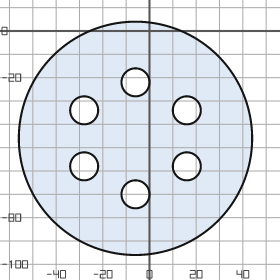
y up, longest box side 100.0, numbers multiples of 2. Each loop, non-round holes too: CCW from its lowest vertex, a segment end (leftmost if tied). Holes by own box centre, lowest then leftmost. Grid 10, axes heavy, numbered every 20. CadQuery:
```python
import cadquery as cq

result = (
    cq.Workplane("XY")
    .moveTo(-6.0, -46.0)
    .circle(50.0)
    .moveTo(-6.0, -70.0)
    .circle(6.0)
    .moveTo(-28.0, -58.0)
    .circle(6.0)
    .moveTo(16.0, -58.0)
    .circle(6.0)
    .moveTo(-28.0, -34.0)
    .circle(6.0)
    .moveTo(16.0, -34.0)
    .circle(6.0)
    .moveTo(-6.0, -22.0)
    .circle(6.0)
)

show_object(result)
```